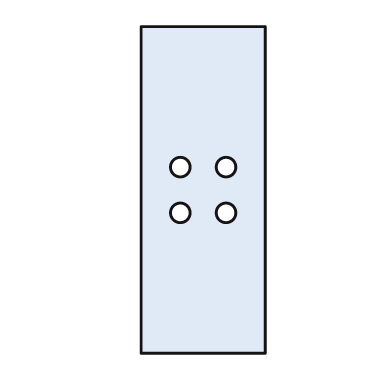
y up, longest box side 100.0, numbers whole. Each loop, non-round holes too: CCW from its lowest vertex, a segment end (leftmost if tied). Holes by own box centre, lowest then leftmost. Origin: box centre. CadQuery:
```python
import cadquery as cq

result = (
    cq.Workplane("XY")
    .moveTo(-19.0, -50.0)
    .lineTo(19.0, -50.0)
    .lineTo(19.0, 50.0)
    .lineTo(-19.0, 50.0)
    .close()
    .moveTo(-7.0, -7.0)
    .circle(3.0)
    .moveTo(7.0, -7.0)
    .circle(3.0)
    .moveTo(-7.0, 7.0)
    .circle(3.0)
    .moveTo(7.0, 7.0)
    .circle(3.0)
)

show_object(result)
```